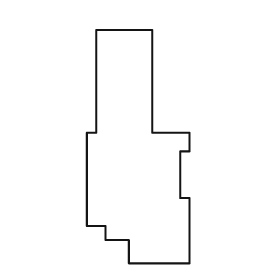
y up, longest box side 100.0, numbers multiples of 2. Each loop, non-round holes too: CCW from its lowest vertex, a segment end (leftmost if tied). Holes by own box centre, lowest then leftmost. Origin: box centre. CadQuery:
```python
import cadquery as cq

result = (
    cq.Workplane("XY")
    .moveTo(-4.0, -50.0)
    .lineTo(22.0, -50.0)
    .lineTo(22.0, -22.0)
    .lineTo(18.0, -22.0)
    .lineTo(18.0, -2.0)
    .lineTo(22.0, -2.0)
    .lineTo(22.0, 6.0)
    .lineTo(6.0, 6.0)
    .lineTo(6.0, 50.0)
    .lineTo(-18.0, 50.0)
    .lineTo(-18.0, 6.0)
    .lineTo(-22.0, 6.0)
    .lineTo(-22.0, -34.0)
    .lineTo(-14.0, -34.0)
    .lineTo(-14.0, -40.0)
    .lineTo(-4.0, -40.0)
    .close()
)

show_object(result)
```